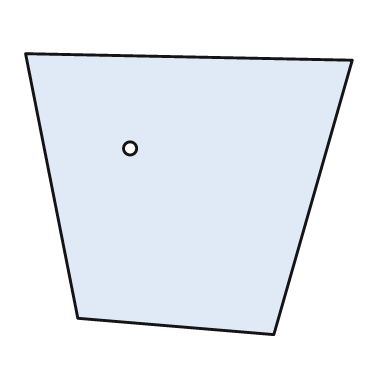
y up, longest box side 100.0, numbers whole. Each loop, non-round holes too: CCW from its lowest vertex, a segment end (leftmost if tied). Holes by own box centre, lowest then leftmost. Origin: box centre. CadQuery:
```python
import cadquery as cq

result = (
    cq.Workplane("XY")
    .moveTo(26.0, -43.0)
    .lineTo(50.0, 41.0)
    .lineTo(-50.0, 43.0)
    .lineTo(-34.0, -38.0)
    .close()
    .moveTo(-18.0, 14.0)
    .circle(2.0)
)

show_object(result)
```